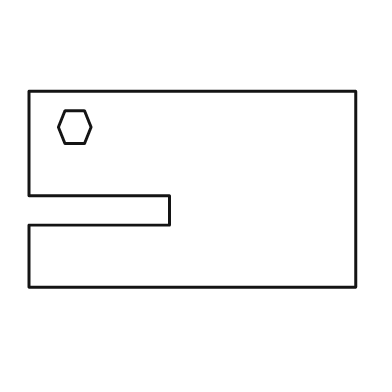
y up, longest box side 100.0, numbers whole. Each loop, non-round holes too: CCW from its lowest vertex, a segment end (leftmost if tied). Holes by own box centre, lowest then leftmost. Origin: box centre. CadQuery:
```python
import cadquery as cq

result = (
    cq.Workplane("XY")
    .moveTo(-50.0, -30.0)
    .lineTo(50.0, -30.0)
    .lineTo(50.0, 30.0)
    .lineTo(-50.0, 30.0)
    .lineTo(-50.0, -2.0)
    .lineTo(-7.0, -2.0)
    .lineTo(-7.0, -11.0)
    .lineTo(-50.0, -11.0)
    .close()
    .moveTo(-39.0, 14.0)
    .lineTo(-33.0, 14.0)
    .lineTo(-31.0, 19.0)
    .lineTo(-33.0, 24.0)
    .lineTo(-39.0, 24.0)
    .lineTo(-41.0, 19.0)
    .close()
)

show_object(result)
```